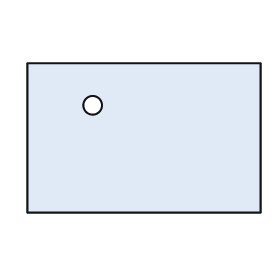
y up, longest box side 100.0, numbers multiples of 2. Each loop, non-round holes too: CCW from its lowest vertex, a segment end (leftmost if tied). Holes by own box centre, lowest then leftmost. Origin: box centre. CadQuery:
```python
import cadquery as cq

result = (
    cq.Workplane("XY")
    .moveTo(-50.0, -32.0)
    .lineTo(50.0, -32.0)
    .lineTo(50.0, 32.0)
    .lineTo(-50.0, 32.0)
    .close()
    .moveTo(-22.0, 14.0)
    .circle(4.0)
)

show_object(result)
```